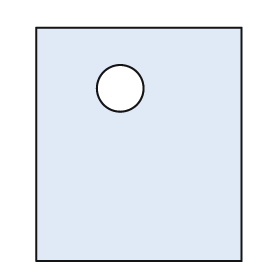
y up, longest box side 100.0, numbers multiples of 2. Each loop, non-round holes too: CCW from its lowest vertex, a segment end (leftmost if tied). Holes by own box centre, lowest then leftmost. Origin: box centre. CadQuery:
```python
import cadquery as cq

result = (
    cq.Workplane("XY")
    .moveTo(-44.0, -50.0)
    .lineTo(44.0, -50.0)
    .lineTo(44.0, 50.0)
    .lineTo(-44.0, 50.0)
    .close()
    .moveTo(-8.0, 24.0)
    .circle(10.0)
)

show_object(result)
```